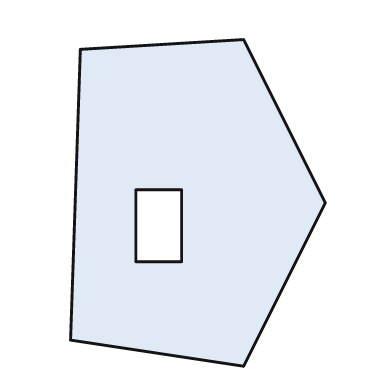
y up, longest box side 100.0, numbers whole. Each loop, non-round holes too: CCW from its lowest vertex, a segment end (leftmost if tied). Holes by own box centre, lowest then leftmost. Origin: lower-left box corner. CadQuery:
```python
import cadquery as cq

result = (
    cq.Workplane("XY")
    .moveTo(53.0, 0.0)
    .lineTo(78.0, 50.0)
    .lineTo(53.0, 100.0)
    .lineTo(3.0, 97.0)
    .lineTo(0.0, 8.0)
    .close()
    .moveTo(20.0, 32.0)
    .lineTo(34.0, 32.0)
    .lineTo(34.0, 54.0)
    .lineTo(20.0, 54.0)
    .close()
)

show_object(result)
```